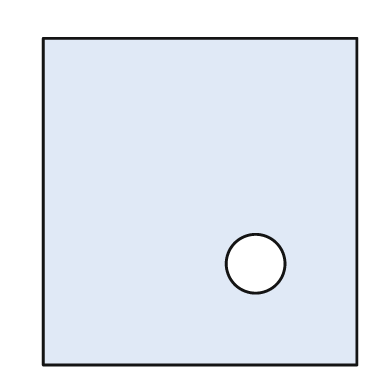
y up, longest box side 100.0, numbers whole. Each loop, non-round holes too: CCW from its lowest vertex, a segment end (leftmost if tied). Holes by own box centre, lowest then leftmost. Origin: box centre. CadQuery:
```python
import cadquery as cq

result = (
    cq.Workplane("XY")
    .moveTo(-48.0, -50.0)
    .lineTo(48.0, -50.0)
    .lineTo(48.0, 50.0)
    .lineTo(-48.0, 50.0)
    .close()
    .moveTo(17.0, -19.0)
    .circle(9.0)
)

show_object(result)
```